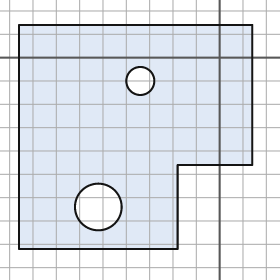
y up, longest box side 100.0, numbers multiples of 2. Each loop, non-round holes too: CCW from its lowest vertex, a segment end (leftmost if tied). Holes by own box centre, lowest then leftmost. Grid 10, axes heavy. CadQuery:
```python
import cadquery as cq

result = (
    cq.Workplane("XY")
    .moveTo(-86.0, -82.0)
    .lineTo(-18.0, -82.0)
    .lineTo(-18.0, -46.0)
    .lineTo(14.0, -46.0)
    .lineTo(14.0, 14.0)
    .lineTo(-86.0, 14.0)
    .close()
    .moveTo(-52.0, -64.0)
    .circle(10.0)
    .moveTo(-34.0, -10.0)
    .circle(6.0)
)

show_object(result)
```